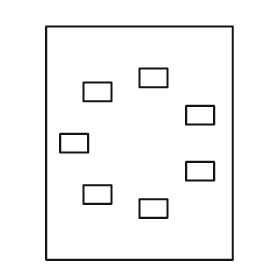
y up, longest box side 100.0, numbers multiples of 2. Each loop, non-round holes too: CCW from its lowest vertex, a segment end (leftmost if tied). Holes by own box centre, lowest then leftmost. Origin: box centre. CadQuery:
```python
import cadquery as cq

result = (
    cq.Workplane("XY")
    .moveTo(-40.0, -50.0)
    .lineTo(40.0, -50.0)
    .lineTo(40.0, 50.0)
    .lineTo(-40.0, 50.0)
    .close()
    .moveTo(0.0, -32.0)
    .lineTo(12.0, -32.0)
    .lineTo(12.0, -24.0)
    .lineTo(0.0, -24.0)
    .close()
    .moveTo(-24.0, -26.0)
    .lineTo(-12.0, -26.0)
    .lineTo(-12.0, -18.0)
    .lineTo(-24.0, -18.0)
    .close()
    .moveTo(20.0, -16.0)
    .lineTo(32.0, -16.0)
    .lineTo(32.0, -8.0)
    .lineTo(20.0, -8.0)
    .close()
    .moveTo(-34.0, -4.0)
    .lineTo(-22.0, -4.0)
    .lineTo(-22.0, 4.0)
    .lineTo(-34.0, 4.0)
    .close()
    .moveTo(20.0, 8.0)
    .lineTo(32.0, 8.0)
    .lineTo(32.0, 16.0)
    .lineTo(20.0, 16.0)
    .close()
    .moveTo(-24.0, 18.0)
    .lineTo(-12.0, 18.0)
    .lineTo(-12.0, 26.0)
    .lineTo(-24.0, 26.0)
    .close()
    .moveTo(0.0, 24.0)
    .lineTo(12.0, 24.0)
    .lineTo(12.0, 32.0)
    .lineTo(0.0, 32.0)
    .close()
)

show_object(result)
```